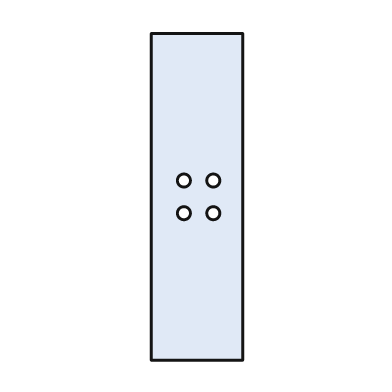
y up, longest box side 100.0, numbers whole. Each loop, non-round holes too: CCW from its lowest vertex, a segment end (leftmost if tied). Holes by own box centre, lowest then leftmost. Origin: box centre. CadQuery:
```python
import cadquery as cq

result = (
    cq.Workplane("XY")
    .moveTo(-14.0, -50.0)
    .lineTo(14.0, -50.0)
    .lineTo(14.0, 50.0)
    .lineTo(-14.0, 50.0)
    .close()
    .moveTo(-4.0, -5.0)
    .circle(2.0)
    .moveTo(5.0, -5.0)
    .circle(2.0)
    .moveTo(-4.0, 5.0)
    .circle(2.0)
    .moveTo(5.0, 5.0)
    .circle(2.0)
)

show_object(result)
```